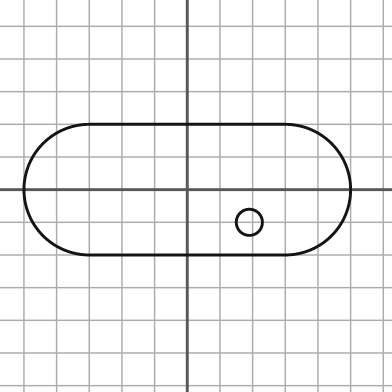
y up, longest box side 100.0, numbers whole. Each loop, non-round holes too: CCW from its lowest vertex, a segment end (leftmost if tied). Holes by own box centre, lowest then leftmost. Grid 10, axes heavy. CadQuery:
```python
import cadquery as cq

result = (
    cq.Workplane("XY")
    .moveTo(-30.0, -20.0)
    .lineTo(30.0, -20.0)
    .threePointArc((50.0, 0.0), (30.0, 20.0))
    .lineTo(-30.0, 20.0)
    .threePointArc((-50.0, 0.0), (-30.0, -20.0))
    .close()
    .moveTo(19.0, -10.0)
    .circle(4.0)
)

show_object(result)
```